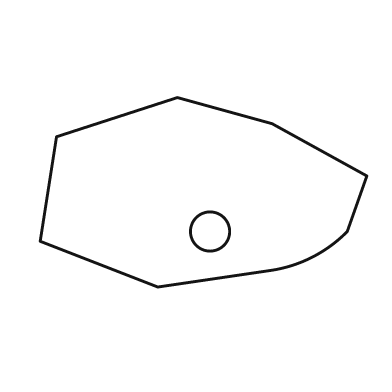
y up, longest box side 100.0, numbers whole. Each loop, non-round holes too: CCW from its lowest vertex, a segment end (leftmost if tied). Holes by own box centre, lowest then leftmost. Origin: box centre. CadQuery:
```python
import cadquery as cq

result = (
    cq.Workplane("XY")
    .moveTo(-14.0, -29.0)
    .lineTo(20.0, -24.0)
    .threePointArc((33.0, -20.0), (44.0, -12.0))
    .lineTo(50.0, 5.0)
    .lineTo(21.0, 21.0)
    .lineTo(-8.0, 29.0)
    .lineTo(-45.0, 17.0)
    .lineTo(-50.0, -15.0)
    .close()
    .moveTo(2.0, -12.0)
    .circle(6.0)
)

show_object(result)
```